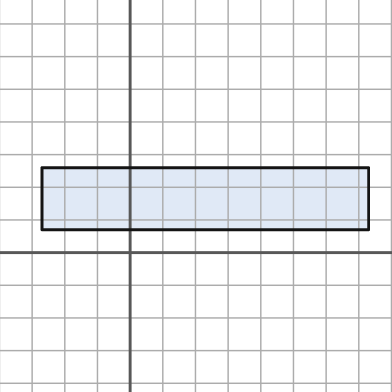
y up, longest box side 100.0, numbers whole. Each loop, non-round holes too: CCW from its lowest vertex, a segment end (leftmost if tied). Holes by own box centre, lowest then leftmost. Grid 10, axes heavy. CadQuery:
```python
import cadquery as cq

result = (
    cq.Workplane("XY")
    .moveTo(-27.0, 7.0)
    .lineTo(73.0, 7.0)
    .lineTo(73.0, 26.0)
    .lineTo(-27.0, 26.0)
    .close()
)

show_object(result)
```